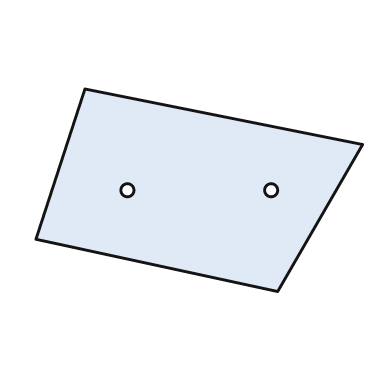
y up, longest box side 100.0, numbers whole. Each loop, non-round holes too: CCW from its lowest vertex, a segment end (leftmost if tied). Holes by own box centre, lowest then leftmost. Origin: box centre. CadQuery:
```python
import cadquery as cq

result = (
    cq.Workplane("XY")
    .moveTo(24.0, -31.0)
    .lineTo(50.0, 14.0)
    .lineTo(-35.0, 31.0)
    .lineTo(-50.0, -15.0)
    .close()
    .moveTo(-22.0, 0.0)
    .circle(2.0)
    .moveTo(22.0, 0.0)
    .circle(2.0)
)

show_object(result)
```